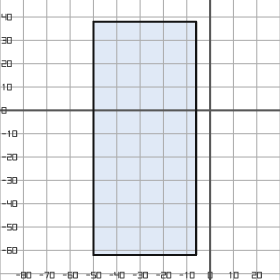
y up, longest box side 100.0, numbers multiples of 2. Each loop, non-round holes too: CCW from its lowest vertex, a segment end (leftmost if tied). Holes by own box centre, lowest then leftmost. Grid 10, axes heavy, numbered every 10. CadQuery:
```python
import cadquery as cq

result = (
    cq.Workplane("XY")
    .moveTo(-50.0, -62.0)
    .lineTo(-6.0, -62.0)
    .lineTo(-6.0, 38.0)
    .lineTo(-50.0, 38.0)
    .close()
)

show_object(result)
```